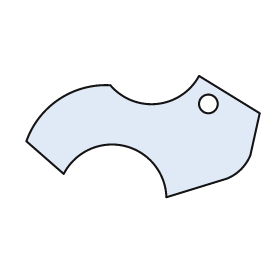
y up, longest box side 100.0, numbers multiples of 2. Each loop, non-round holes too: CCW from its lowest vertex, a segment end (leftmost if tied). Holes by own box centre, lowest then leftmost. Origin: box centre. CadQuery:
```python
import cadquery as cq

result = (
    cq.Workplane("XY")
    .moveTo(10.0, -26.0)
    .lineTo(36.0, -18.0)
    .threePointArc((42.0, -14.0), (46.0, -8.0))
    .lineTo(50.0, 10.0)
    .lineTo(24.0, 26.0)
    .threePointArc((6.0, 14.0), (-14.0, 22.0))
    .threePointArc((-36.0, 16.0), (-50.0, -2.0))
    .lineTo(-34.0, -16.0)
    .threePointArc((-8.0, -4.0), (10.0, -26.0))
    .close()
    .moveTo(28.0, 14.0)
    .circle(4.0)
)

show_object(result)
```